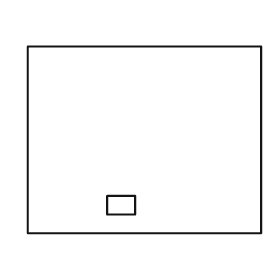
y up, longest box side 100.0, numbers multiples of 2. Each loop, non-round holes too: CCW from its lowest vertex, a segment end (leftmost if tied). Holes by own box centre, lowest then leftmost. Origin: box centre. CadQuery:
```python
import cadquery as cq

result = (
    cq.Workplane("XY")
    .moveTo(-50.0, -40.0)
    .lineTo(50.0, -40.0)
    .lineTo(50.0, 40.0)
    .lineTo(-50.0, 40.0)
    .close()
    .moveTo(-16.0, -32.0)
    .lineTo(-4.0, -32.0)
    .lineTo(-4.0, -24.0)
    .lineTo(-16.0, -24.0)
    .close()
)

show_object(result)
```